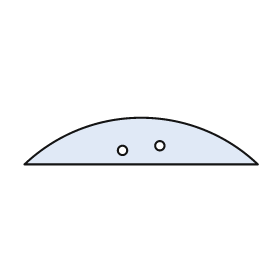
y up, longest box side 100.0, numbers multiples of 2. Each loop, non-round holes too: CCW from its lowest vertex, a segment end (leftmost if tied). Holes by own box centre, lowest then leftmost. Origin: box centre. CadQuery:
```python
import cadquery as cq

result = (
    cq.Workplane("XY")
    .moveTo(-50.0, -10.0)
    .lineTo(50.0, -10.0)
    .threePointArc((0.0, 10.0), (-50.0, -10.0))
    .close()
    .moveTo(-8.0, -4.0)
    .circle(2.0)
    .moveTo(8.0, -2.0)
    .circle(2.0)
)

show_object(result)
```